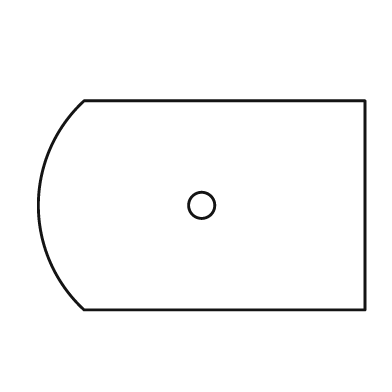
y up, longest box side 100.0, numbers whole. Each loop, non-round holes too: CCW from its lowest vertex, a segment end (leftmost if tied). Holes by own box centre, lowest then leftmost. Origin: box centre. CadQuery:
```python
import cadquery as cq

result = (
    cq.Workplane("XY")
    .moveTo(-36.0, -32.0)
    .lineTo(50.0, -32.0)
    .lineTo(50.0, 32.0)
    .lineTo(-36.0, 32.0)
    .threePointArc((-50.0, 0.0), (-36.0, -32.0))
    .close()
    .moveTo(0.0, 0.0)
    .circle(4.0)
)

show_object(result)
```